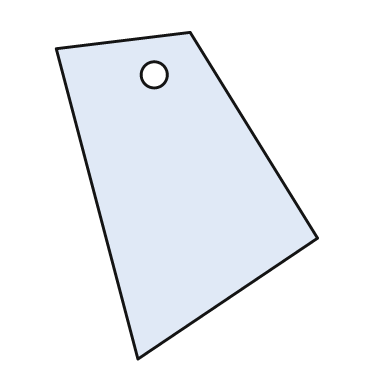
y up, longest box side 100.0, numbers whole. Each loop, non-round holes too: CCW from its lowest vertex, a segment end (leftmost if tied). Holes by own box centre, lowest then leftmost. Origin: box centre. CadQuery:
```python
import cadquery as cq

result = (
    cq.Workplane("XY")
    .moveTo(-15.0, -50.0)
    .lineTo(40.0, -13.0)
    .lineTo(1.0, 50.0)
    .lineTo(-40.0, 45.0)
    .close()
    .moveTo(-10.0, 37.0)
    .circle(4.0)
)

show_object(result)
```